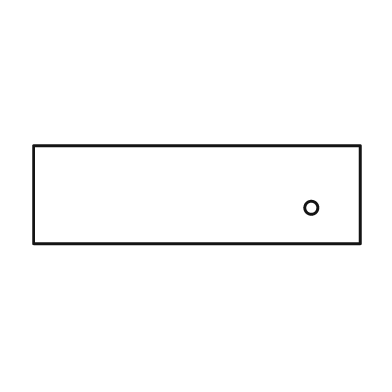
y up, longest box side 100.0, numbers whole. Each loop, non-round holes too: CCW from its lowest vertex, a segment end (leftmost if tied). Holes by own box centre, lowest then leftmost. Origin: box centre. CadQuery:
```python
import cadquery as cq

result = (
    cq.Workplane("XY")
    .moveTo(-50.0, -15.0)
    .lineTo(50.0, -15.0)
    .lineTo(50.0, 15.0)
    .lineTo(-50.0, 15.0)
    .close()
    .moveTo(35.0, -4.0)
    .circle(2.0)
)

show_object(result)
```